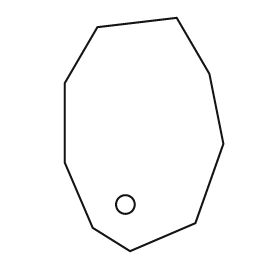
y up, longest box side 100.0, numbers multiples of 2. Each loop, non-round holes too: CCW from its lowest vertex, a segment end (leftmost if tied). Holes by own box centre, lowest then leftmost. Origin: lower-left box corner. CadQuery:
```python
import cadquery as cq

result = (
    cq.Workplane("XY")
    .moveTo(28.0, 0.0)
    .lineTo(56.0, 12.0)
    .lineTo(68.0, 46.0)
    .lineTo(62.0, 76.0)
    .lineTo(48.0, 100.0)
    .lineTo(14.0, 96.0)
    .lineTo(0.0, 72.0)
    .lineTo(0.0, 38.0)
    .lineTo(12.0, 10.0)
    .close()
    .moveTo(26.0, 20.0)
    .circle(4.0)
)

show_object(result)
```